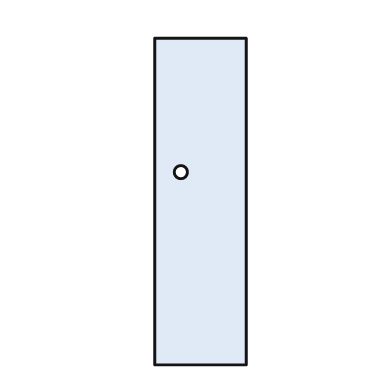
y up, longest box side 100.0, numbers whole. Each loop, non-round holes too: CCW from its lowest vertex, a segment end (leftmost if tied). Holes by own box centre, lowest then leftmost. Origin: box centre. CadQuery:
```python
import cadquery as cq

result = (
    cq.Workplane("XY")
    .moveTo(-14.0, -50.0)
    .lineTo(14.0, -50.0)
    .lineTo(14.0, 50.0)
    .lineTo(-14.0, 50.0)
    .close()
    .moveTo(-6.0, 9.0)
    .circle(2.0)
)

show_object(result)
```